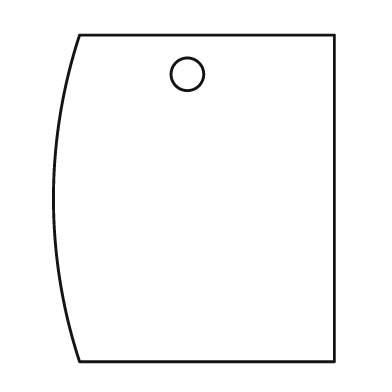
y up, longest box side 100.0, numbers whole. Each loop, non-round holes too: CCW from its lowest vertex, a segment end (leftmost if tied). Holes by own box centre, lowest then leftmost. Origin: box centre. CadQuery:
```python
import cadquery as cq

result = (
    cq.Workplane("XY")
    .moveTo(-35.0, -50.0)
    .lineTo(43.0, -50.0)
    .lineTo(43.0, 50.0)
    .lineTo(-35.0, 50.0)
    .threePointArc((-43.0, 0.0), (-35.0, -50.0))
    .close()
    .moveTo(-2.0, 38.0)
    .circle(5.0)
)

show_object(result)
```